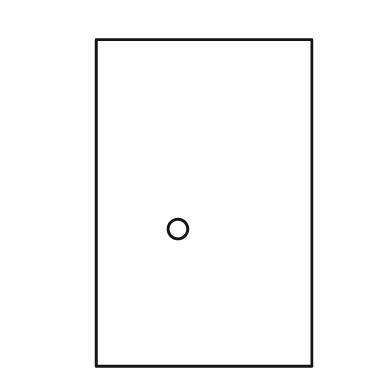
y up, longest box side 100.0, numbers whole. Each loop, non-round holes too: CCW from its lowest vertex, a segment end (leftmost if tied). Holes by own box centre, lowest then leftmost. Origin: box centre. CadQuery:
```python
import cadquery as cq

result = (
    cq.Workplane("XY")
    .moveTo(-33.0, -50.0)
    .lineTo(33.0, -50.0)
    .lineTo(33.0, 50.0)
    .lineTo(-33.0, 50.0)
    .close()
    .moveTo(-8.0, -8.0)
    .circle(3.0)
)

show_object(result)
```